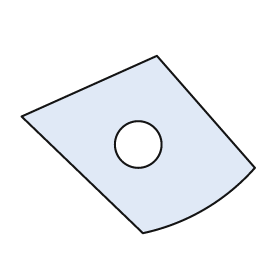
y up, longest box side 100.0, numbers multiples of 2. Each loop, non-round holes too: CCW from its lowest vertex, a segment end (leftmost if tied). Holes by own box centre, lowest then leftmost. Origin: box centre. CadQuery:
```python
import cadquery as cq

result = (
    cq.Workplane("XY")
    .moveTo(2.0, -38.0)
    .threePointArc((28.0, -28.0), (50.0, -10.0))
    .lineTo(8.0, 38.0)
    .lineTo(-50.0, 12.0)
    .close()
    .moveTo(0.0, 0.0)
    .circle(10.0)
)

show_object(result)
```